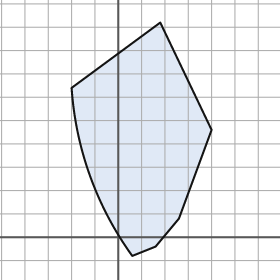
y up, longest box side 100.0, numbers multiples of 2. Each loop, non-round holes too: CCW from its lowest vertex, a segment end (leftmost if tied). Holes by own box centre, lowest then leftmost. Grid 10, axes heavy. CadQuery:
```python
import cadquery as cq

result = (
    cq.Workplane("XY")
    .moveTo(6.0, -8.0)
    .lineTo(16.0, -4.0)
    .lineTo(26.0, 8.0)
    .lineTo(40.0, 46.0)
    .lineTo(18.0, 92.0)
    .lineTo(-20.0, 64.0)
    .threePointArc((-12.0, 26.0), (6.0, -8.0))
    .close()
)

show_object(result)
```